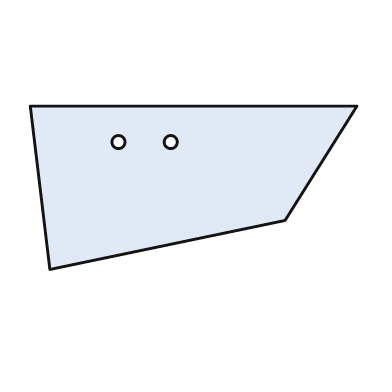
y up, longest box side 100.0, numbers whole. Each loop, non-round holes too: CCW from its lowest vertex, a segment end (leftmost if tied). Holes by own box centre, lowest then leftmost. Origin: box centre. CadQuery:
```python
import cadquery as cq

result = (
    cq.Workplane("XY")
    .moveTo(-44.0, -25.0)
    .lineTo(28.0, -10.0)
    .lineTo(50.0, 25.0)
    .lineTo(-50.0, 25.0)
    .close()
    .moveTo(-23.0, 14.0)
    .circle(2.0)
    .moveTo(-7.0, 14.0)
    .circle(2.0)
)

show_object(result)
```